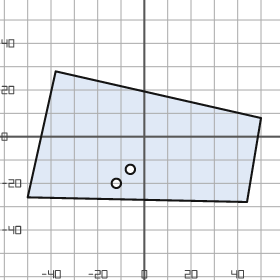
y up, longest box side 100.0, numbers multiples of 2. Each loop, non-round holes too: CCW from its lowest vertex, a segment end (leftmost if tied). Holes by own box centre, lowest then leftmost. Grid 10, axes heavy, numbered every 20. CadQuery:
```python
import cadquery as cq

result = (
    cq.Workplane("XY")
    .moveTo(44.0, -28.0)
    .lineTo(50.0, 8.0)
    .lineTo(-38.0, 28.0)
    .lineTo(-50.0, -26.0)
    .close()
    .moveTo(-12.0, -20.0)
    .circle(2.0)
    .moveTo(-6.0, -14.0)
    .circle(2.0)
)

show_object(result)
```